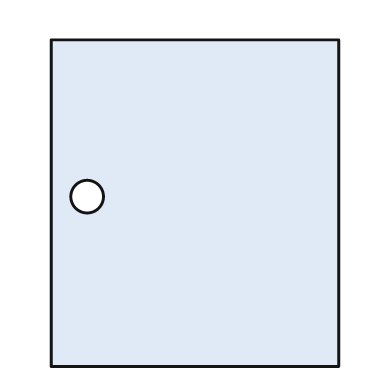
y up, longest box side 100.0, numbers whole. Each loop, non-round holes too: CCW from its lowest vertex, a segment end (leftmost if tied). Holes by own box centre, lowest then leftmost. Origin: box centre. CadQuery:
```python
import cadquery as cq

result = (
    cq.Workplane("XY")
    .moveTo(-44.0, -50.0)
    .lineTo(44.0, -50.0)
    .lineTo(44.0, 50.0)
    .lineTo(-44.0, 50.0)
    .close()
    .moveTo(-33.0, 2.0)
    .circle(5.0)
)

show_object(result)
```